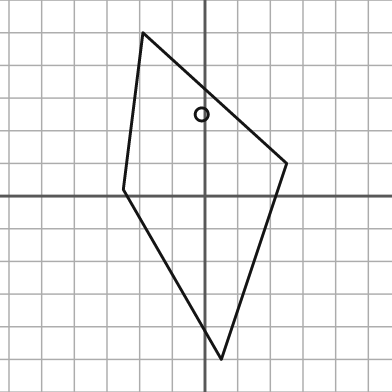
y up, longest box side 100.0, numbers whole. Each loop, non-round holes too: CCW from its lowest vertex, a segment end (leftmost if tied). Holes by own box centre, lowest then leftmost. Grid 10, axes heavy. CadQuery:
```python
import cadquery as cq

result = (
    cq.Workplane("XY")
    .moveTo(5.0, -50.0)
    .lineTo(25.0, 10.0)
    .lineTo(-19.0, 50.0)
    .lineTo(-25.0, 2.0)
    .close()
    .moveTo(-1.0, 25.0)
    .circle(2.0)
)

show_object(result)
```